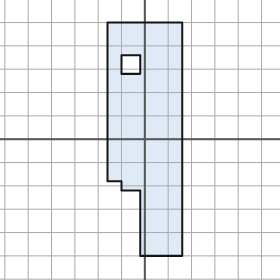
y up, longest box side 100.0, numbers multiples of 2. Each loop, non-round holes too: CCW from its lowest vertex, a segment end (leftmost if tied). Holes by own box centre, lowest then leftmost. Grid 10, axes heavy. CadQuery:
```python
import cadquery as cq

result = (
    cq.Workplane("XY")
    .moveTo(-2.0, -50.0)
    .lineTo(16.0, -50.0)
    .lineTo(16.0, 50.0)
    .lineTo(-16.0, 50.0)
    .lineTo(-16.0, -18.0)
    .lineTo(-10.0, -18.0)
    .lineTo(-10.0, -22.0)
    .lineTo(-2.0, -22.0)
    .close()
    .moveTo(-10.0, 28.0)
    .lineTo(-2.0, 28.0)
    .lineTo(-2.0, 36.0)
    .lineTo(-10.0, 36.0)
    .close()
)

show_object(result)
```